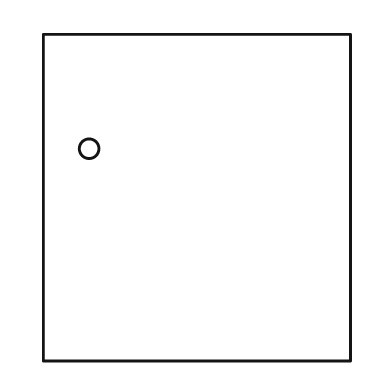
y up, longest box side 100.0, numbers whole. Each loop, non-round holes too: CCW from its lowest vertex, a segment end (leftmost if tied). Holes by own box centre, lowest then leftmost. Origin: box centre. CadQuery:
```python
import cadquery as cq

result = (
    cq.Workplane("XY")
    .moveTo(-47.0, -50.0)
    .lineTo(47.0, -50.0)
    .lineTo(47.0, 50.0)
    .lineTo(-47.0, 50.0)
    .close()
    .moveTo(-33.0, 15.0)
    .circle(3.0)
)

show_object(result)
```